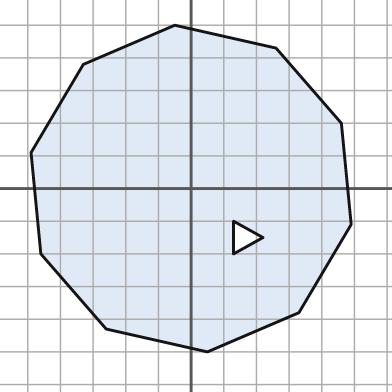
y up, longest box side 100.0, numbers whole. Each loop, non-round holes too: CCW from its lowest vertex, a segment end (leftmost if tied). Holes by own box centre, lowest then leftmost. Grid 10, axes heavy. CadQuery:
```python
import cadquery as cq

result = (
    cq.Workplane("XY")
    .moveTo(5.0, -50.0)
    .lineTo(33.0, -38.0)
    .lineTo(49.0, -11.0)
    .lineTo(46.0, 20.0)
    .lineTo(26.0, 43.0)
    .lineTo(-5.0, 50.0)
    .lineTo(-33.0, 38.0)
    .lineTo(-49.0, 11.0)
    .lineTo(-46.0, -20.0)
    .lineTo(-26.0, -43.0)
    .close()
    .moveTo(13.0, -20.0)
    .lineTo(22.0, -15.0)
    .lineTo(13.0, -10.0)
    .close()
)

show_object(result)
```